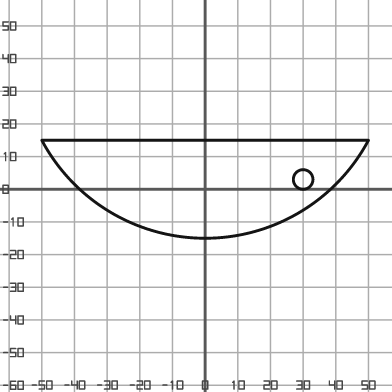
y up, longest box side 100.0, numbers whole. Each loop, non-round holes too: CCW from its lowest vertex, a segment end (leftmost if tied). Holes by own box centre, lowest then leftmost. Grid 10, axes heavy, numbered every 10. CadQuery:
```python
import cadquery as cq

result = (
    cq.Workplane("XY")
    .moveTo(-50.0, 15.0)
    .threePointArc((0.0, -15.0), (50.0, 15.0))
    .close()
    .moveTo(30.0, 3.0)
    .circle(3.0)
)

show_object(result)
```